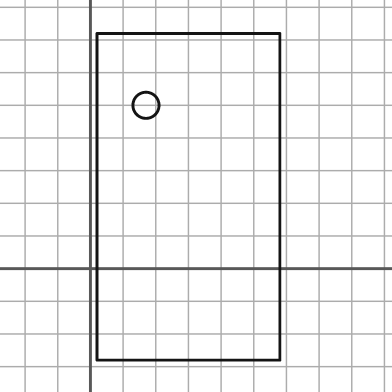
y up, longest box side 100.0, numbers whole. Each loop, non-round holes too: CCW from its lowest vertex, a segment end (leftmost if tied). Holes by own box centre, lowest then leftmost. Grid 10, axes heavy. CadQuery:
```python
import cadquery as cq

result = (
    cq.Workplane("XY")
    .moveTo(2.0, -28.0)
    .lineTo(58.0, -28.0)
    .lineTo(58.0, 72.0)
    .lineTo(2.0, 72.0)
    .close()
    .moveTo(17.0, 50.0)
    .circle(4.0)
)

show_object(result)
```